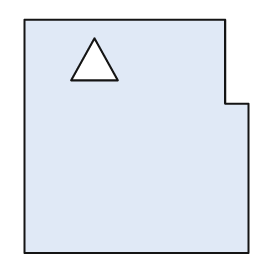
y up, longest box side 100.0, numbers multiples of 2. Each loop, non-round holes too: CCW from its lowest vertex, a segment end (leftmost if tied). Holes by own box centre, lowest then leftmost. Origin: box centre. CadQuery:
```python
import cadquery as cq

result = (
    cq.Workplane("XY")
    .moveTo(-48.0, -50.0)
    .lineTo(48.0, -50.0)
    .lineTo(48.0, 14.0)
    .lineTo(38.0, 14.0)
    .lineTo(38.0, 50.0)
    .lineTo(-48.0, 50.0)
    .close()
    .moveTo(-28.0, 24.0)
    .lineTo(-8.0, 24.0)
    .lineTo(-18.0, 42.0)
    .close()
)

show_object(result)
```